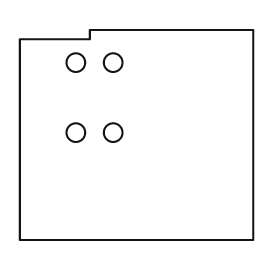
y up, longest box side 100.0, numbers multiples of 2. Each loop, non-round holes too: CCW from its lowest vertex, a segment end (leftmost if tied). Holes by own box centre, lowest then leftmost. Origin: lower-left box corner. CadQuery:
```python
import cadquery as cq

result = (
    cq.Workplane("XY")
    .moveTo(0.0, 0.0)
    .lineTo(100.0, 0.0)
    .lineTo(100.0, 90.0)
    .lineTo(30.0, 90.0)
    .lineTo(30.0, 86.0)
    .lineTo(0.0, 86.0)
    .close()
    .moveTo(24.0, 46.0)
    .circle(4.0)
    .moveTo(40.0, 46.0)
    .circle(4.0)
    .moveTo(24.0, 76.0)
    .circle(4.0)
    .moveTo(40.0, 76.0)
    .circle(4.0)
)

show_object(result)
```